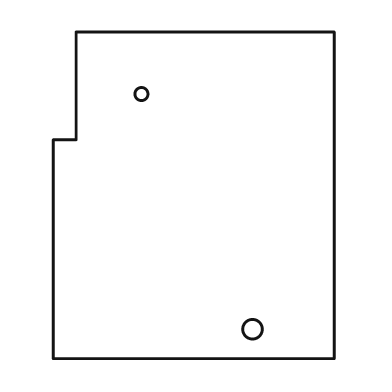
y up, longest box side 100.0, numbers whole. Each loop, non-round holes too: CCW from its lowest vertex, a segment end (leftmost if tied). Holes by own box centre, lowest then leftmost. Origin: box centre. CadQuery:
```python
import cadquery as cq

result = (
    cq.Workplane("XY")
    .moveTo(-43.0, -50.0)
    .lineTo(43.0, -50.0)
    .lineTo(43.0, 50.0)
    .lineTo(-36.0, 50.0)
    .lineTo(-36.0, 17.0)
    .lineTo(-43.0, 17.0)
    .close()
    .moveTo(18.0, -41.0)
    .circle(3.0)
    .moveTo(-16.0, 31.0)
    .circle(2.0)
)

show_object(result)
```